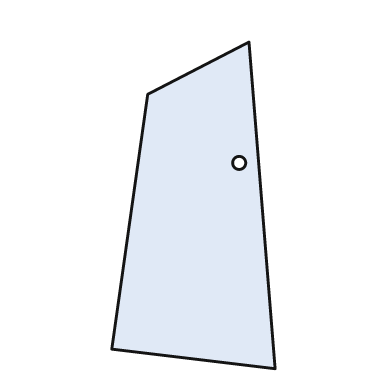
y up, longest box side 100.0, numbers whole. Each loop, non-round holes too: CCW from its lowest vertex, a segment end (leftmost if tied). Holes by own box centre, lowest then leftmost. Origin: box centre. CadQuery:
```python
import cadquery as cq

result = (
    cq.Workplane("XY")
    .moveTo(25.0, -50.0)
    .lineTo(17.0, 50.0)
    .lineTo(-14.0, 34.0)
    .lineTo(-25.0, -44.0)
    .close()
    .moveTo(14.0, 13.0)
    .circle(2.0)
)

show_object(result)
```